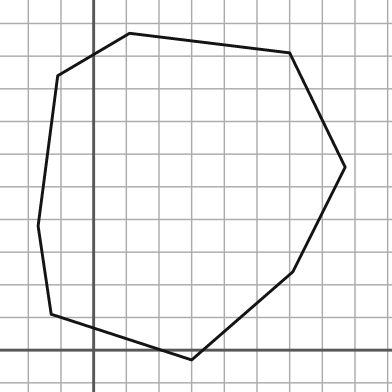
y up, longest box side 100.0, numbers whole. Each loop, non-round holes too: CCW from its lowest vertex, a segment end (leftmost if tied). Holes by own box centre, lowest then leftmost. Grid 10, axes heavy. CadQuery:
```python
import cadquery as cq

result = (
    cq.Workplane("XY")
    .moveTo(30.0, -3.0)
    .lineTo(61.0, 24.0)
    .lineTo(77.0, 56.0)
    .lineTo(60.0, 91.0)
    .lineTo(11.0, 97.0)
    .lineTo(-11.0, 84.0)
    .lineTo(-17.0, 38.0)
    .lineTo(-13.0, 11.0)
    .close()
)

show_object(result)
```